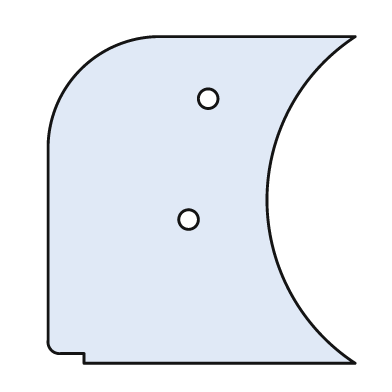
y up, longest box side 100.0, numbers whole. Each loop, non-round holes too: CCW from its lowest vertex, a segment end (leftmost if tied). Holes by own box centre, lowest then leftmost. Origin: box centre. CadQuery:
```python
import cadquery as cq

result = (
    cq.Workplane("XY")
    .moveTo(-36.0, -50.0)
    .lineTo(47.0, -50.0)
    .threePointArc((20.0, 0.0), (47.0, 50.0))
    .lineTo(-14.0, 50.0)
    .threePointArc((-37.0, 40.0), (-47.0, 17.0))
    .lineTo(-47.0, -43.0)
    .threePointArc((-46.0, -46.0), (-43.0, -47.0))
    .lineTo(-36.0, -47.0)
    .close()
    .moveTo(-4.0, -6.0)
    .circle(3.0)
    .moveTo(2.0, 31.0)
    .circle(3.0)
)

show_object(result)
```